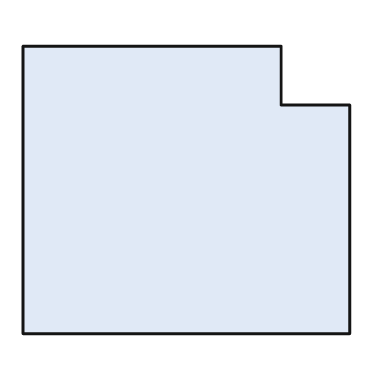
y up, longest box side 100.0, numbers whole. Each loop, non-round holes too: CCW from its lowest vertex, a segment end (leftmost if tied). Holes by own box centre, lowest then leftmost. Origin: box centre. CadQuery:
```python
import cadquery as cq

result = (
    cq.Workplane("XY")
    .moveTo(-50.0, -44.0)
    .lineTo(50.0, -44.0)
    .lineTo(50.0, 26.0)
    .lineTo(29.0, 26.0)
    .lineTo(29.0, 44.0)
    .lineTo(-50.0, 44.0)
    .close()
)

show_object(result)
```